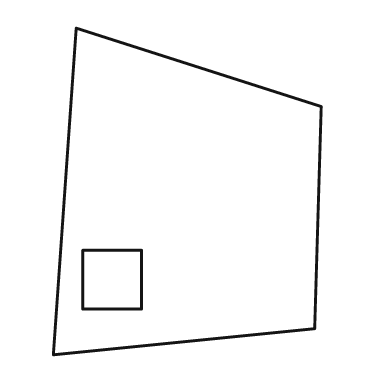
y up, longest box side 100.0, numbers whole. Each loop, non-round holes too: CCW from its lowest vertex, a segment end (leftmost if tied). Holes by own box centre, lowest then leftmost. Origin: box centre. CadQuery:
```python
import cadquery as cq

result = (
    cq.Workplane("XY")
    .moveTo(-41.0, -50.0)
    .lineTo(39.0, -42.0)
    .lineTo(41.0, 26.0)
    .lineTo(-34.0, 50.0)
    .close()
    .moveTo(-32.0, -36.0)
    .lineTo(-14.0, -36.0)
    .lineTo(-14.0, -18.0)
    .lineTo(-32.0, -18.0)
    .close()
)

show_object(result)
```